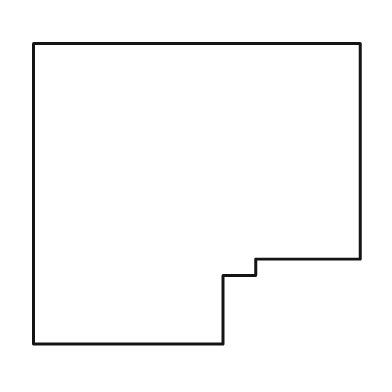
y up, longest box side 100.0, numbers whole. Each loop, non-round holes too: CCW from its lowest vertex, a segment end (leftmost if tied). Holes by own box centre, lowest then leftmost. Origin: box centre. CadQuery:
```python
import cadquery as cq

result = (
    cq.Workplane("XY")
    .moveTo(-50.0, -46.0)
    .lineTo(8.0, -46.0)
    .lineTo(8.0, -25.0)
    .lineTo(18.0, -25.0)
    .lineTo(18.0, -20.0)
    .lineTo(50.0, -20.0)
    .lineTo(50.0, 46.0)
    .lineTo(-50.0, 46.0)
    .close()
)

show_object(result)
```